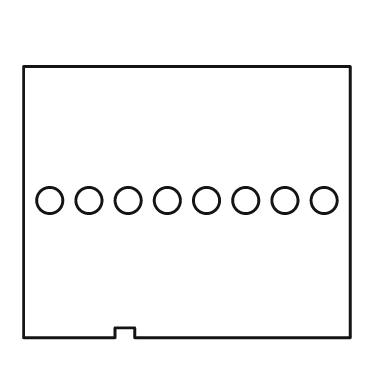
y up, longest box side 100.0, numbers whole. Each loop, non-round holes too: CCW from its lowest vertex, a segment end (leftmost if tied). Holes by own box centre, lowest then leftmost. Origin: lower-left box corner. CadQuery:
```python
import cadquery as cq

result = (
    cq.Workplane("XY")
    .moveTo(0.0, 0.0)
    .lineTo(28.0, 0.0)
    .lineTo(28.0, 3.0)
    .lineTo(34.0, 3.0)
    .lineTo(34.0, 0.0)
    .lineTo(100.0, 0.0)
    .lineTo(100.0, 83.0)
    .lineTo(0.0, 83.0)
    .close()
    .moveTo(8.0, 42.0)
    .circle(4.0)
    .moveTo(20.0, 42.0)
    .circle(4.0)
    .moveTo(32.0, 42.0)
    .circle(4.0)
    .moveTo(44.0, 42.0)
    .circle(4.0)
    .moveTo(56.0, 42.0)
    .circle(4.0)
    .moveTo(68.0, 42.0)
    .circle(4.0)
    .moveTo(80.0, 42.0)
    .circle(4.0)
    .moveTo(92.0, 42.0)
    .circle(4.0)
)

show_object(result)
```